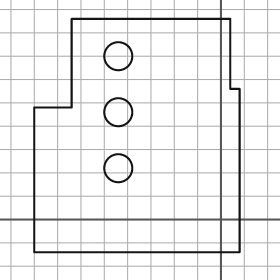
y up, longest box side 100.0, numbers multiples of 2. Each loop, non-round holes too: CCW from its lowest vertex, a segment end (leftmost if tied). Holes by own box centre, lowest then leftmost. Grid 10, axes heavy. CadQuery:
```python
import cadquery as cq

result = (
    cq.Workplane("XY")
    .moveTo(-80.0, -14.0)
    .lineTo(8.0, -14.0)
    .lineTo(8.0, 56.0)
    .lineTo(4.0, 56.0)
    .lineTo(4.0, 86.0)
    .lineTo(-64.0, 86.0)
    .lineTo(-64.0, 48.0)
    .lineTo(-80.0, 48.0)
    .close()
    .moveTo(-44.0, 22.0)
    .circle(6.0)
    .moveTo(-44.0, 46.0)
    .circle(6.0)
    .moveTo(-44.0, 70.0)
    .circle(6.0)
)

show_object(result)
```